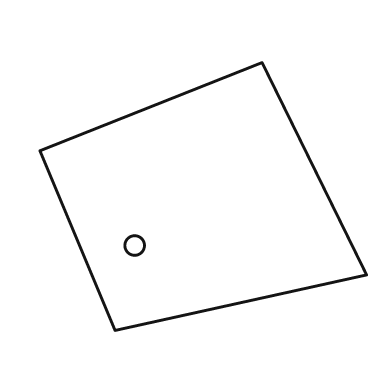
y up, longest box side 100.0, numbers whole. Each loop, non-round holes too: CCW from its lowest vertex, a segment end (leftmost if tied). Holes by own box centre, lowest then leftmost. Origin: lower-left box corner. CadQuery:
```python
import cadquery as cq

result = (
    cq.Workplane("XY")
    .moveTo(23.0, 0.0)
    .lineTo(100.0, 17.0)
    .lineTo(68.0, 82.0)
    .lineTo(0.0, 55.0)
    .close()
    .moveTo(29.0, 26.0)
    .circle(3.0)
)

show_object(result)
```